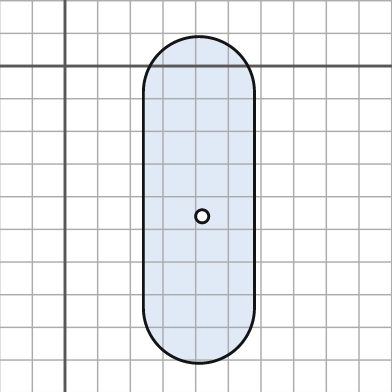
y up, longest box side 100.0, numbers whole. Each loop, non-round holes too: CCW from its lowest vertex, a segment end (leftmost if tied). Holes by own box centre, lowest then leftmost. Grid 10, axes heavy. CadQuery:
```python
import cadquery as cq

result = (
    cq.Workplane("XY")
    .moveTo(24.0, -74.0)
    .threePointArc((41.0, -91.0), (58.0, -74.0))
    .lineTo(58.0, -8.0)
    .threePointArc((41.0, 9.0), (24.0, -8.0))
    .close()
    .moveTo(42.0, -46.0)
    .circle(2.0)
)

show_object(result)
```